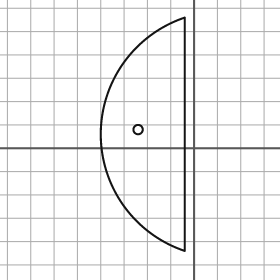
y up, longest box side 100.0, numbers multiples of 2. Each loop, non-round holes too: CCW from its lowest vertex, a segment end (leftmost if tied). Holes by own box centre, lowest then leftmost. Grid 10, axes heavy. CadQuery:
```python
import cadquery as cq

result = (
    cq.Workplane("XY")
    .moveTo(-4.0, -44.0)
    .lineTo(-4.0, 56.0)
    .threePointArc((-40.0, 6.0), (-4.0, -44.0))
    .close()
    .moveTo(-24.0, 8.0)
    .circle(2.0)
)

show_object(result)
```